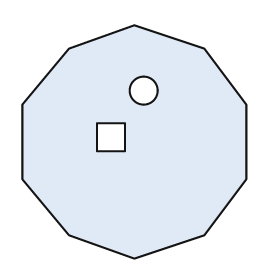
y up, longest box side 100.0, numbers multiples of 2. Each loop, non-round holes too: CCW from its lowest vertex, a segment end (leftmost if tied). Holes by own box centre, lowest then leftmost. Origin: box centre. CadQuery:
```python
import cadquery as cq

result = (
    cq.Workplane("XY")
    .moveTo(0.0, -50.0)
    .lineTo(30.0, -40.0)
    .lineTo(48.0, -16.0)
    .lineTo(48.0, 16.0)
    .lineTo(30.0, 40.0)
    .lineTo(0.0, 50.0)
    .lineTo(-28.0, 40.0)
    .lineTo(-48.0, 16.0)
    .lineTo(-48.0, -16.0)
    .lineTo(-28.0, -40.0)
    .close()
    .moveTo(-16.0, -4.0)
    .lineTo(-4.0, -4.0)
    .lineTo(-4.0, 8.0)
    .lineTo(-16.0, 8.0)
    .close()
    .moveTo(4.0, 22.0)
    .circle(6.0)
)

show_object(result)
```